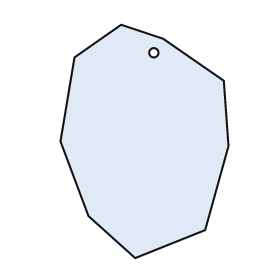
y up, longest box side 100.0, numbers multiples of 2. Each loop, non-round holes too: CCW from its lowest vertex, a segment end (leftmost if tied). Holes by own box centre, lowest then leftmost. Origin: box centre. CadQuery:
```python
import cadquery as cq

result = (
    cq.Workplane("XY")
    .moveTo(-4.0, -50.0)
    .lineTo(26.0, -38.0)
    .lineTo(36.0, -2.0)
    .lineTo(34.0, 26.0)
    .lineTo(8.0, 44.0)
    .lineTo(-10.0, 50.0)
    .lineTo(-30.0, 36.0)
    .lineTo(-36.0, 0.0)
    .lineTo(-24.0, -32.0)
    .close()
    .moveTo(4.0, 38.0)
    .circle(2.0)
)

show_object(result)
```